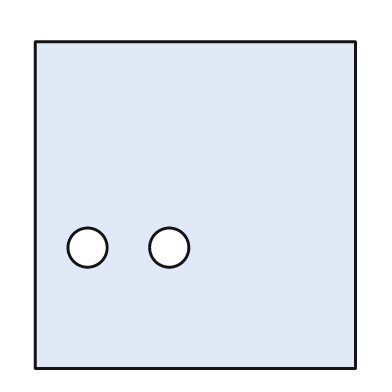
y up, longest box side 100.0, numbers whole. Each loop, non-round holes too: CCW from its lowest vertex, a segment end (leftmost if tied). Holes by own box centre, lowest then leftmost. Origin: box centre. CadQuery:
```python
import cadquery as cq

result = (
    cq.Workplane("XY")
    .moveTo(-49.0, -50.0)
    .lineTo(49.0, -50.0)
    .lineTo(49.0, 50.0)
    .lineTo(-49.0, 50.0)
    .close()
    .moveTo(-33.0, -13.0)
    .circle(6.0)
    .moveTo(-8.0, -13.0)
    .circle(6.0)
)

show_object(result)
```